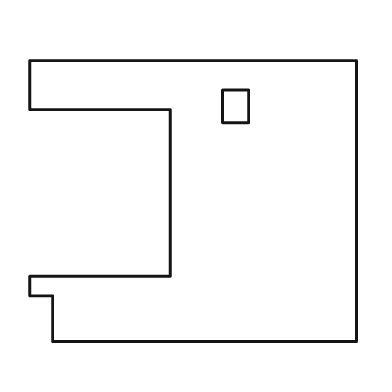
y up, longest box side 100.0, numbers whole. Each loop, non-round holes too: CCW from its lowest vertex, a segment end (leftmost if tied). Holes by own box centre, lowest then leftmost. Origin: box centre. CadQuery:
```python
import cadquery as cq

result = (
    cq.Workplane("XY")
    .moveTo(-43.0, -43.0)
    .lineTo(50.0, -43.0)
    .lineTo(50.0, 43.0)
    .lineTo(-50.0, 43.0)
    .lineTo(-50.0, 28.0)
    .lineTo(-7.0, 28.0)
    .lineTo(-7.0, -23.0)
    .lineTo(-50.0, -23.0)
    .lineTo(-50.0, -29.0)
    .lineTo(-43.0, -29.0)
    .close()
    .moveTo(9.0, 24.0)
    .lineTo(17.0, 24.0)
    .lineTo(17.0, 34.0)
    .lineTo(9.0, 34.0)
    .close()
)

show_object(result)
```